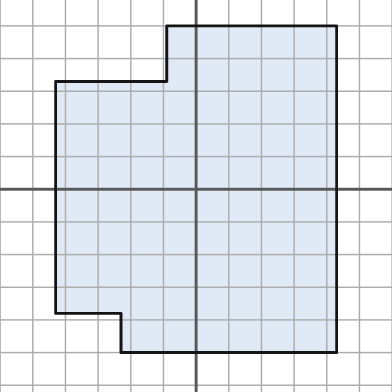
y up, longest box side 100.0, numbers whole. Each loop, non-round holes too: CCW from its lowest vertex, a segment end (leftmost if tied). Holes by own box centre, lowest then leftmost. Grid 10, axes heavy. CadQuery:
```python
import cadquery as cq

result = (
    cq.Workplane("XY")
    .moveTo(-23.0, -50.0)
    .lineTo(43.0, -50.0)
    .lineTo(43.0, 50.0)
    .lineTo(-9.0, 50.0)
    .lineTo(-9.0, 33.0)
    .lineTo(-43.0, 33.0)
    .lineTo(-43.0, -38.0)
    .lineTo(-23.0, -38.0)
    .close()
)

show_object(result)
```